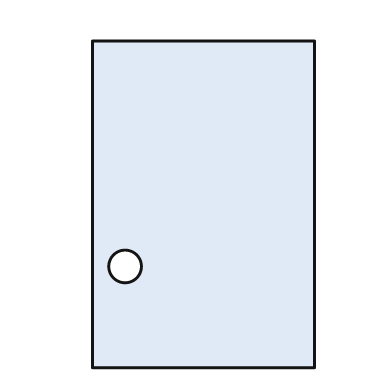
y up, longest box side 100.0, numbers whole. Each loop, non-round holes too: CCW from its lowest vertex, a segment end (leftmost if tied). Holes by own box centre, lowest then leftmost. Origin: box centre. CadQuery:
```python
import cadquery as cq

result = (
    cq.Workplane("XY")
    .moveTo(-34.0, -50.0)
    .lineTo(34.0, -50.0)
    .lineTo(34.0, 50.0)
    .lineTo(-34.0, 50.0)
    .close()
    .moveTo(-24.0, -19.0)
    .circle(5.0)
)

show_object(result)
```